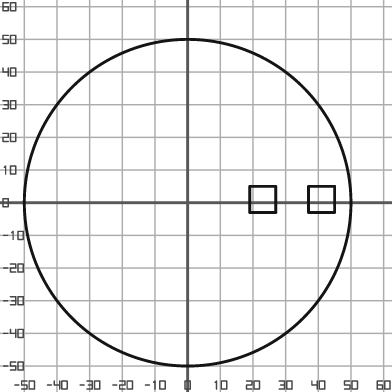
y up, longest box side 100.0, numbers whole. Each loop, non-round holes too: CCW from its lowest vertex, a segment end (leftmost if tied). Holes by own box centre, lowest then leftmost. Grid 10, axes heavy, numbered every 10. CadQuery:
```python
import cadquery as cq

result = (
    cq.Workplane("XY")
    .moveTo(0.0, 0.0)
    .circle(50.0)
    .moveTo(19.0, -3.0)
    .lineTo(27.0, -3.0)
    .lineTo(27.0, 5.0)
    .lineTo(19.0, 5.0)
    .close()
    .moveTo(37.0, -3.0)
    .lineTo(45.0, -3.0)
    .lineTo(45.0, 5.0)
    .lineTo(37.0, 5.0)
    .close()
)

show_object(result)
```